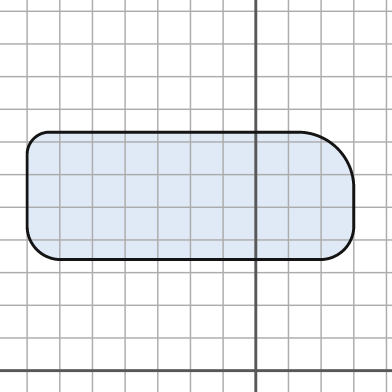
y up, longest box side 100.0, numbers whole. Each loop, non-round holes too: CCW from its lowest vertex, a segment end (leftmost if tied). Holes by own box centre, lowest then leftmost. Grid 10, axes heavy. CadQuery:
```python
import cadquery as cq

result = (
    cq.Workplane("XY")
    .moveTo(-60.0, 34.0)
    .lineTo(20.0, 34.0)
    .threePointArc((27.0, 37.0), (30.0, 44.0))
    .lineTo(30.0, 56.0)
    .threePointArc((25.0, 68.0), (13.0, 73.0))
    .lineTo(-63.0, 73.0)
    .threePointArc((-68.0, 71.0), (-70.0, 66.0))
    .lineTo(-70.0, 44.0)
    .threePointArc((-67.0, 37.0), (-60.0, 34.0))
    .close()
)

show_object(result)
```